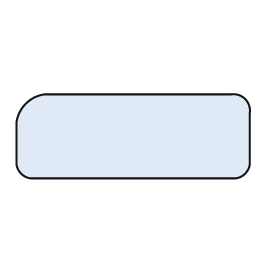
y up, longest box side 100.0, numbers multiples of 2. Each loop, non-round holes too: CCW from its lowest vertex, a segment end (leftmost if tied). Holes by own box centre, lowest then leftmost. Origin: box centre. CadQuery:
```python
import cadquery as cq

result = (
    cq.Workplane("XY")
    .moveTo(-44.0, -18.0)
    .lineTo(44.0, -18.0)
    .threePointArc((48.0, -16.0), (50.0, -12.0))
    .lineTo(50.0, 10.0)
    .threePointArc((48.0, 16.0), (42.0, 18.0))
    .lineTo(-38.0, 18.0)
    .threePointArc((-46.0, 14.0), (-50.0, 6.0))
    .lineTo(-50.0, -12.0)
    .threePointArc((-48.0, -16.0), (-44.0, -18.0))
    .close()
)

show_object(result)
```